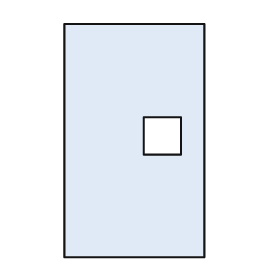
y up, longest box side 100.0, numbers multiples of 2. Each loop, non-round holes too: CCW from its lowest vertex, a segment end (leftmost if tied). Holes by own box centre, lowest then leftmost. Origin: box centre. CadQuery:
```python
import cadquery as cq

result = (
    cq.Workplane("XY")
    .moveTo(-30.0, -50.0)
    .lineTo(30.0, -50.0)
    .lineTo(30.0, 50.0)
    .lineTo(-30.0, 50.0)
    .close()
    .moveTo(4.0, -6.0)
    .lineTo(20.0, -6.0)
    .lineTo(20.0, 10.0)
    .lineTo(4.0, 10.0)
    .close()
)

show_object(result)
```